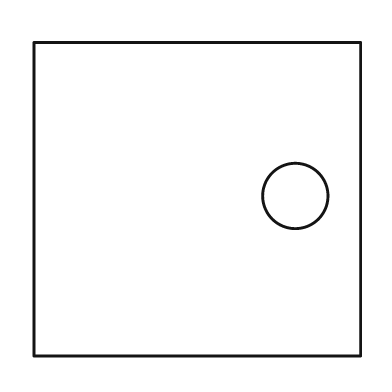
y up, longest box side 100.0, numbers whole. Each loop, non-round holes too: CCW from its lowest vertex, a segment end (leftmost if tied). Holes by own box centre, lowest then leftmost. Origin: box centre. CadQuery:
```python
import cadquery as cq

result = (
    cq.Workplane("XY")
    .moveTo(-50.0, -48.0)
    .lineTo(50.0, -48.0)
    .lineTo(50.0, 48.0)
    .lineTo(-50.0, 48.0)
    .close()
    .moveTo(30.0, 1.0)
    .circle(10.0)
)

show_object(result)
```